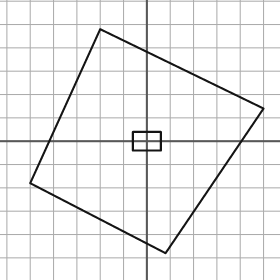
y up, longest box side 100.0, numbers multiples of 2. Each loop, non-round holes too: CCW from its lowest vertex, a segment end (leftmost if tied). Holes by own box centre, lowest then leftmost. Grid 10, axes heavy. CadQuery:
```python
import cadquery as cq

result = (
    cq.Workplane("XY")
    .moveTo(8.0, -48.0)
    .lineTo(50.0, 14.0)
    .lineTo(-20.0, 48.0)
    .lineTo(-50.0, -18.0)
    .close()
    .moveTo(-6.0, -4.0)
    .lineTo(6.0, -4.0)
    .lineTo(6.0, 4.0)
    .lineTo(-6.0, 4.0)
    .close()
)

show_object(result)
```